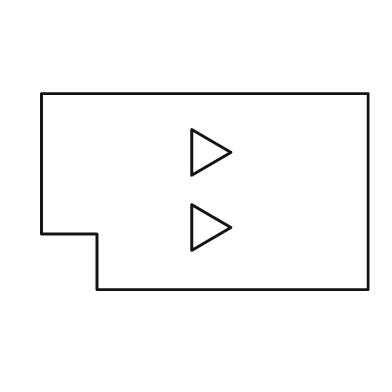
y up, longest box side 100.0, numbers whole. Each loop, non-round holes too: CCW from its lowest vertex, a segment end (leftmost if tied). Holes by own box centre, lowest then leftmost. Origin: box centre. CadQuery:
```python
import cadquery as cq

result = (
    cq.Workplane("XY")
    .moveTo(-33.0, -30.0)
    .lineTo(50.0, -30.0)
    .lineTo(50.0, 30.0)
    .lineTo(-50.0, 30.0)
    .lineTo(-50.0, -13.0)
    .lineTo(-33.0, -13.0)
    .close()
    .moveTo(-4.0, -18.0)
    .lineTo(8.0, -11.0)
    .lineTo(-4.0, -4.0)
    .close()
    .moveTo(-4.0, 5.0)
    .lineTo(8.0, 12.0)
    .lineTo(-4.0, 19.0)
    .close()
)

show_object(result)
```